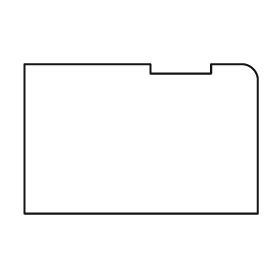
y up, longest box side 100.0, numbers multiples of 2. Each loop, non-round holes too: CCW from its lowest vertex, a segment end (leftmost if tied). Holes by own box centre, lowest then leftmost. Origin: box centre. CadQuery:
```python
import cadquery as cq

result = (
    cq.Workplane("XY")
    .moveTo(-50.0, -32.0)
    .lineTo(50.0, -32.0)
    .lineTo(50.0, 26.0)
    .threePointArc((48.0, 30.0), (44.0, 32.0))
    .lineTo(30.0, 32.0)
    .lineTo(30.0, 28.0)
    .lineTo(4.0, 28.0)
    .lineTo(4.0, 32.0)
    .lineTo(-50.0, 32.0)
    .close()
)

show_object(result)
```